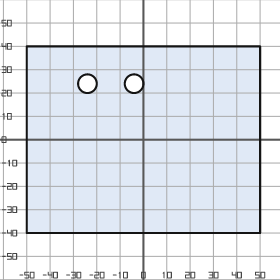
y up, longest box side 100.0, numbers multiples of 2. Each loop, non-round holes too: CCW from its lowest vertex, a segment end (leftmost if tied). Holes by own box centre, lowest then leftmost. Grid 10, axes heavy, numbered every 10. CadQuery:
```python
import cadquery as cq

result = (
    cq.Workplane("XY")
    .moveTo(-50.0, -40.0)
    .lineTo(50.0, -40.0)
    .lineTo(50.0, 40.0)
    .lineTo(-50.0, 40.0)
    .close()
    .moveTo(-24.0, 24.0)
    .circle(4.0)
    .moveTo(-4.0, 24.0)
    .circle(4.0)
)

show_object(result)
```